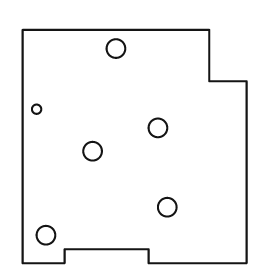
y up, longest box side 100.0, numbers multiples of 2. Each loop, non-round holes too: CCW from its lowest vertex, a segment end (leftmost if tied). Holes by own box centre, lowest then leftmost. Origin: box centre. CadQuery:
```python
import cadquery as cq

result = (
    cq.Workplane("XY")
    .moveTo(-48.0, -50.0)
    .lineTo(-30.0, -50.0)
    .lineTo(-30.0, -44.0)
    .lineTo(6.0, -44.0)
    .lineTo(6.0, -50.0)
    .lineTo(48.0, -50.0)
    .lineTo(48.0, 28.0)
    .lineTo(32.0, 28.0)
    .lineTo(32.0, 50.0)
    .lineTo(-48.0, 50.0)
    .close()
    .moveTo(-38.0, -38.0)
    .circle(4.0)
    .moveTo(14.0, -26.0)
    .circle(4.0)
    .moveTo(-18.0, -2.0)
    .circle(4.0)
    .moveTo(10.0, 8.0)
    .circle(4.0)
    .moveTo(-42.0, 16.0)
    .circle(2.0)
    .moveTo(-8.0, 42.0)
    .circle(4.0)
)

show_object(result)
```